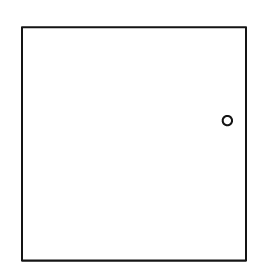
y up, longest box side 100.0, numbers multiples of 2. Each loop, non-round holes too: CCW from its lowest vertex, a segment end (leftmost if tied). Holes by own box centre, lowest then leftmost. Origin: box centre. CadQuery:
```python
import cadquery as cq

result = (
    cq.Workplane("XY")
    .moveTo(-48.0, -50.0)
    .lineTo(48.0, -50.0)
    .lineTo(48.0, 50.0)
    .lineTo(-48.0, 50.0)
    .close()
    .moveTo(40.0, 10.0)
    .circle(2.0)
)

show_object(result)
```